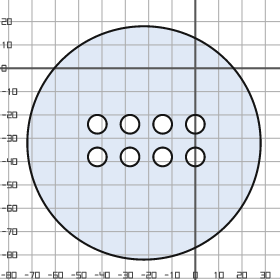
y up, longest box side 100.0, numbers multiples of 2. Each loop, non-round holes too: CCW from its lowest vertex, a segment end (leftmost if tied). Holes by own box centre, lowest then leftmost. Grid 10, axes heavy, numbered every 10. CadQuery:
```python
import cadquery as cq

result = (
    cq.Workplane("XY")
    .moveTo(-22.0, -32.0)
    .circle(50.0)
    .moveTo(-42.0, -38.0)
    .circle(4.0)
    .moveTo(-28.0, -38.0)
    .circle(4.0)
    .moveTo(-14.0, -38.0)
    .circle(4.0)
    .moveTo(0.0, -38.0)
    .circle(4.0)
    .moveTo(-42.0, -24.0)
    .circle(4.0)
    .moveTo(-28.0, -24.0)
    .circle(4.0)
    .moveTo(-14.0, -24.0)
    .circle(4.0)
    .moveTo(0.0, -24.0)
    .circle(4.0)
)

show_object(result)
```